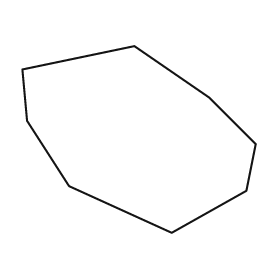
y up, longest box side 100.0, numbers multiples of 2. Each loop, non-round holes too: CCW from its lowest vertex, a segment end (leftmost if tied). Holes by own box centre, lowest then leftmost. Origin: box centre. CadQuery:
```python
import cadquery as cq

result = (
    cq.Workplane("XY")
    .moveTo(14.0, -40.0)
    .lineTo(46.0, -22.0)
    .lineTo(50.0, -2.0)
    .lineTo(30.0, 18.0)
    .lineTo(-2.0, 40.0)
    .lineTo(-50.0, 30.0)
    .lineTo(-48.0, 8.0)
    .lineTo(-30.0, -20.0)
    .close()
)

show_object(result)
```